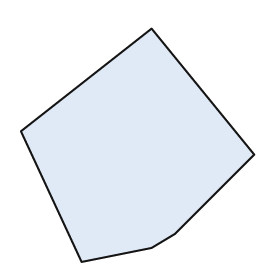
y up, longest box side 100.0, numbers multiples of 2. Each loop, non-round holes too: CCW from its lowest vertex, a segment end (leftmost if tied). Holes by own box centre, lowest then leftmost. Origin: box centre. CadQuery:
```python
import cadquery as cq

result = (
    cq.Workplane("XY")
    .moveTo(-24.0, -50.0)
    .lineTo(6.0, -44.0)
    .lineTo(16.0, -38.0)
    .lineTo(50.0, -4.0)
    .lineTo(6.0, 50.0)
    .lineTo(-50.0, 6.0)
    .close()
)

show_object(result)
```